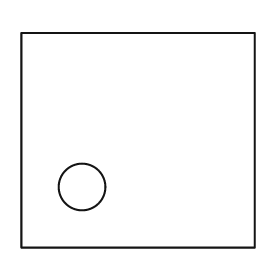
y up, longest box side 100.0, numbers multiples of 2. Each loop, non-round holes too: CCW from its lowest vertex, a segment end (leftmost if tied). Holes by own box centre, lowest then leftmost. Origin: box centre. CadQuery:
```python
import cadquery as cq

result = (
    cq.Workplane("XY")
    .moveTo(-50.0, -46.0)
    .lineTo(50.0, -46.0)
    .lineTo(50.0, 46.0)
    .lineTo(-50.0, 46.0)
    .close()
    .moveTo(-24.0, -20.0)
    .circle(10.0)
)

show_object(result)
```